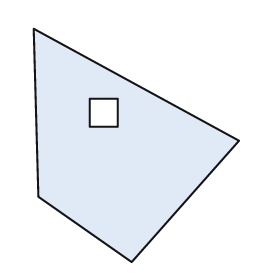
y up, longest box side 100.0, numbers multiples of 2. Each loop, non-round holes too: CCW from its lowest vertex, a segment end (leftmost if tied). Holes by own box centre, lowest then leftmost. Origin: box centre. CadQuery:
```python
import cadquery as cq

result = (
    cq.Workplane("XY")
    .moveTo(-2.0, -50.0)
    .lineTo(44.0, 2.0)
    .lineTo(-44.0, 50.0)
    .lineTo(-42.0, -22.0)
    .close()
    .moveTo(-20.0, 8.0)
    .lineTo(-8.0, 8.0)
    .lineTo(-8.0, 20.0)
    .lineTo(-20.0, 20.0)
    .close()
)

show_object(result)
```